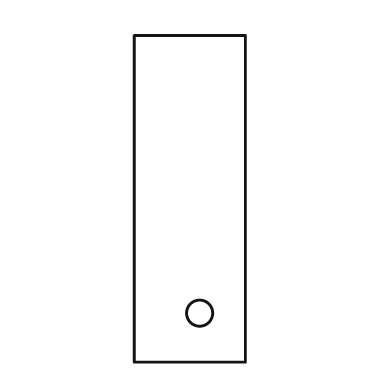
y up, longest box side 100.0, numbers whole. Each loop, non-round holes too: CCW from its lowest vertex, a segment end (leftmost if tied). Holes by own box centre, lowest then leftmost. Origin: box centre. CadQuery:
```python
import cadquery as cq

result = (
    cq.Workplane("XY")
    .moveTo(-17.0, -50.0)
    .lineTo(17.0, -50.0)
    .lineTo(17.0, 50.0)
    .lineTo(-17.0, 50.0)
    .close()
    .moveTo(3.0, -35.0)
    .circle(4.0)
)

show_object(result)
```